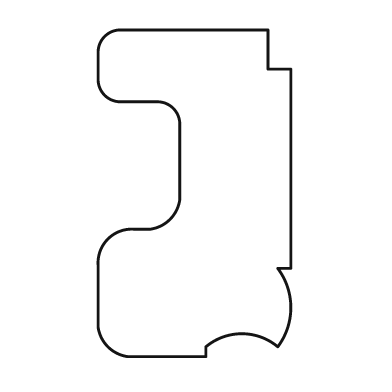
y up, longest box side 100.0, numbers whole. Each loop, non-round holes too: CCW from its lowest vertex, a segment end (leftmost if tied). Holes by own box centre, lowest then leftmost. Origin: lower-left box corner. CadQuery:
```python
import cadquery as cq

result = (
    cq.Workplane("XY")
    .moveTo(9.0, 0.0)
    .lineTo(33.0, 0.0)
    .lineTo(33.0, 3.0)
    .threePointArc((44.0, 7.0), (55.0, 3.0))
    .threePointArc((59.0, 15.0), (55.0, 27.0))
    .lineTo(59.0, 27.0)
    .lineTo(59.0, 88.0)
    .lineTo(52.0, 88.0)
    .lineTo(52.0, 100.0)
    .lineTo(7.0, 100.0)
    .threePointArc((2.0, 98.0), (0.0, 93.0))
    .lineTo(0.0, 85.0)
    .threePointArc((2.0, 80.0), (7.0, 78.0))
    .lineTo(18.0, 78.0)
    .threePointArc((23.0, 76.0), (25.0, 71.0))
    .lineTo(25.0, 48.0)
    .threePointArc((22.0, 42.0), (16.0, 39.0))
    .lineTo(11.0, 39.0)
    .threePointArc((3.0, 36.0), (0.0, 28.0))
    .lineTo(0.0, 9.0)
    .threePointArc((3.0, 3.0), (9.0, 0.0))
    .close()
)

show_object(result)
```